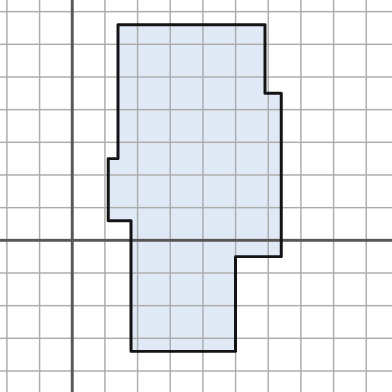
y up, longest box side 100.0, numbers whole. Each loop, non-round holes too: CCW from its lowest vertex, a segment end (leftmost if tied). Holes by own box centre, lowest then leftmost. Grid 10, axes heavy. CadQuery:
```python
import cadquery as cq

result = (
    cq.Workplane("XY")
    .moveTo(18.0, -34.0)
    .lineTo(50.0, -34.0)
    .lineTo(50.0, -5.0)
    .lineTo(64.0, -5.0)
    .lineTo(64.0, 45.0)
    .lineTo(59.0, 45.0)
    .lineTo(59.0, 66.0)
    .lineTo(14.0, 66.0)
    .lineTo(14.0, 25.0)
    .lineTo(11.0, 25.0)
    .lineTo(11.0, 6.0)
    .lineTo(18.0, 6.0)
    .close()
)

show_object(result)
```